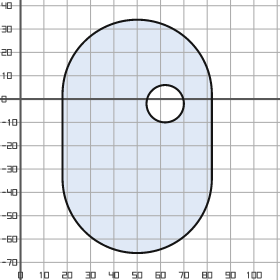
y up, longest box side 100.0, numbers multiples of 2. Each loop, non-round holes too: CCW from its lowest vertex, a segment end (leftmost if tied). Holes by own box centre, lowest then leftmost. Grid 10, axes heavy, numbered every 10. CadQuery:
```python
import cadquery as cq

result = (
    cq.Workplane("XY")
    .moveTo(18.0, -34.0)
    .threePointArc((50.0, -66.0), (82.0, -34.0))
    .lineTo(82.0, 2.0)
    .threePointArc((50.0, 34.0), (18.0, 2.0))
    .close()
    .moveTo(62.0, -2.0)
    .circle(8.0)
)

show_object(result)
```